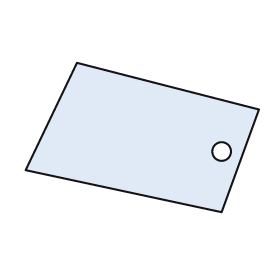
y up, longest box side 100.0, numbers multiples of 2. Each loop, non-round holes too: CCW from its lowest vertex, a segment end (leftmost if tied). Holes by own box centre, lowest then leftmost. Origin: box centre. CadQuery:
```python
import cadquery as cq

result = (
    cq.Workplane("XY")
    .moveTo(34.0, -32.0)
    .lineTo(50.0, 12.0)
    .lineTo(-28.0, 32.0)
    .lineTo(-50.0, -14.0)
    .close()
    .moveTo(34.0, -6.0)
    .circle(4.0)
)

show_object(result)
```